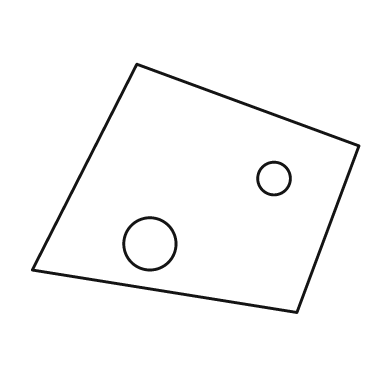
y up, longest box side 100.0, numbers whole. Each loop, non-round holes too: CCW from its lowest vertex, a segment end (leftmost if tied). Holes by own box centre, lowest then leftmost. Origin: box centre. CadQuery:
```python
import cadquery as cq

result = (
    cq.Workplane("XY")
    .moveTo(31.0, -38.0)
    .lineTo(50.0, 13.0)
    .lineTo(-18.0, 38.0)
    .lineTo(-50.0, -25.0)
    .close()
    .moveTo(-14.0, -17.0)
    .circle(8.0)
    .moveTo(24.0, 3.0)
    .circle(5.0)
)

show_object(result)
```